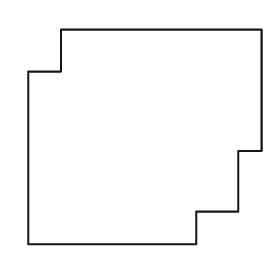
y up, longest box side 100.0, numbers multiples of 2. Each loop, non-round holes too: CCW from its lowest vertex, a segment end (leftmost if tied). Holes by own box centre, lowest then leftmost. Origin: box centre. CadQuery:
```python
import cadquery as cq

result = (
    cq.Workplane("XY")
    .moveTo(-50.0, -46.0)
    .lineTo(22.0, -46.0)
    .lineTo(22.0, -32.0)
    .lineTo(40.0, -32.0)
    .lineTo(40.0, -6.0)
    .lineTo(50.0, -6.0)
    .lineTo(50.0, 46.0)
    .lineTo(-36.0, 46.0)
    .lineTo(-36.0, 28.0)
    .lineTo(-50.0, 28.0)
    .close()
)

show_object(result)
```